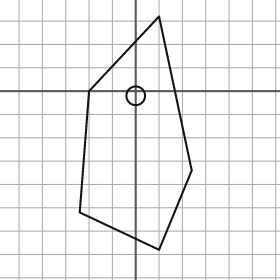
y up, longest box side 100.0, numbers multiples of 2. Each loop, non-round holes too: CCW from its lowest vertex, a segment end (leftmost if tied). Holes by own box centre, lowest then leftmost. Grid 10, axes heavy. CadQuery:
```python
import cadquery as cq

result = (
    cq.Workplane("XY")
    .moveTo(10.0, -68.0)
    .lineTo(24.0, -34.0)
    .lineTo(10.0, 32.0)
    .lineTo(-20.0, 0.0)
    .lineTo(-24.0, -52.0)
    .close()
    .moveTo(0.0, -2.0)
    .circle(4.0)
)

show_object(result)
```